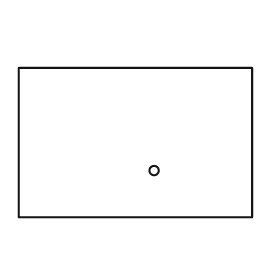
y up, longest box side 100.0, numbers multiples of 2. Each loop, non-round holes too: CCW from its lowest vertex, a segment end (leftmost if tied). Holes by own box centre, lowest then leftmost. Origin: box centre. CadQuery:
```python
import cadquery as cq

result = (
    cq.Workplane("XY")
    .moveTo(-50.0, -32.0)
    .lineTo(50.0, -32.0)
    .lineTo(50.0, 32.0)
    .lineTo(-50.0, 32.0)
    .close()
    .moveTo(8.0, -12.0)
    .circle(2.0)
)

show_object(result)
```